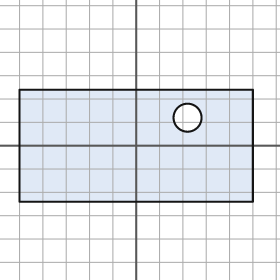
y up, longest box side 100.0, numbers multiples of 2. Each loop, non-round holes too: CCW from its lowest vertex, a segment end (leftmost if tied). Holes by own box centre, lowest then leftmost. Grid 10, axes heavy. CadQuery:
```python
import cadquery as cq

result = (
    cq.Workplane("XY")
    .moveTo(-50.0, -24.0)
    .lineTo(50.0, -24.0)
    .lineTo(50.0, 24.0)
    .lineTo(-50.0, 24.0)
    .close()
    .moveTo(22.0, 12.0)
    .circle(6.0)
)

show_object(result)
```